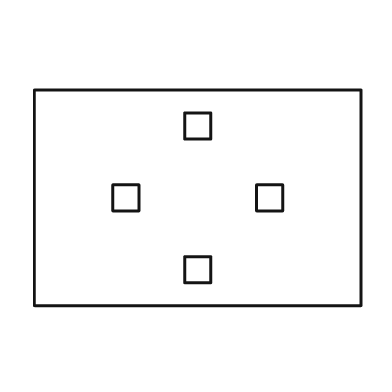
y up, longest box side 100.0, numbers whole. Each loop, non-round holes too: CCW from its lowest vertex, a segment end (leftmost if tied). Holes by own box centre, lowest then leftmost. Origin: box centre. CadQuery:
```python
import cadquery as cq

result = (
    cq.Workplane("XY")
    .moveTo(-50.0, -33.0)
    .lineTo(50.0, -33.0)
    .lineTo(50.0, 33.0)
    .lineTo(-50.0, 33.0)
    .close()
    .moveTo(-4.0, -26.0)
    .lineTo(4.0, -26.0)
    .lineTo(4.0, -18.0)
    .lineTo(-4.0, -18.0)
    .close()
    .moveTo(-26.0, -4.0)
    .lineTo(-18.0, -4.0)
    .lineTo(-18.0, 4.0)
    .lineTo(-26.0, 4.0)
    .close()
    .moveTo(18.0, -4.0)
    .lineTo(26.0, -4.0)
    .lineTo(26.0, 4.0)
    .lineTo(18.0, 4.0)
    .close()
    .moveTo(-4.0, 18.0)
    .lineTo(4.0, 18.0)
    .lineTo(4.0, 26.0)
    .lineTo(-4.0, 26.0)
    .close()
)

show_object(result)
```